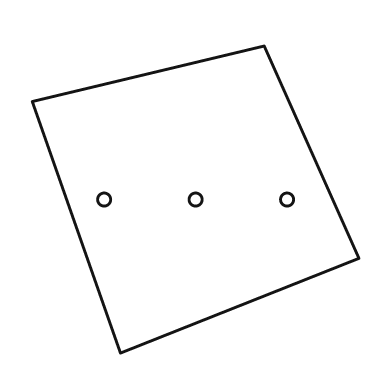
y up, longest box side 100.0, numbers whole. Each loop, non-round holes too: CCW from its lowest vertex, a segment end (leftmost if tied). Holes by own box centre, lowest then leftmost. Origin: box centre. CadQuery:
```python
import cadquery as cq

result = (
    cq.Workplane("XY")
    .moveTo(-23.0, -47.0)
    .lineTo(50.0, -18.0)
    .lineTo(21.0, 47.0)
    .lineTo(-50.0, 30.0)
    .close()
    .moveTo(-28.0, 0.0)
    .circle(2.0)
    .moveTo(0.0, 0.0)
    .circle(2.0)
    .moveTo(28.0, 0.0)
    .circle(2.0)
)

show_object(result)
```